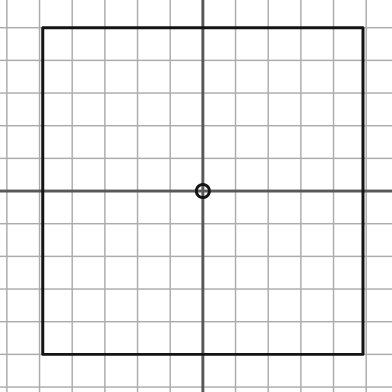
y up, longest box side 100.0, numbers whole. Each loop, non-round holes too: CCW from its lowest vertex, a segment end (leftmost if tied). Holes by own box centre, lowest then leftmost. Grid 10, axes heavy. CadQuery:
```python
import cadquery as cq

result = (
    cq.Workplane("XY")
    .moveTo(-49.0, -50.0)
    .lineTo(49.0, -50.0)
    .lineTo(49.0, 50.0)
    .lineTo(-49.0, 50.0)
    .close()
    .moveTo(0.0, 0.0)
    .circle(2.0)
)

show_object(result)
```